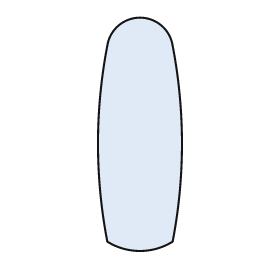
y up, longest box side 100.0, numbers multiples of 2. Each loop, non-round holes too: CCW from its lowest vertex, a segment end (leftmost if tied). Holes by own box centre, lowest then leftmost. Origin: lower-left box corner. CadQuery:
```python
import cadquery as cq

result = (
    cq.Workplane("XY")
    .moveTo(4.0, 4.0)
    .threePointArc((18.0, 0.0), (32.0, 4.0))
    .threePointArc((36.0, 46.0), (32.0, 88.0))
    .threePointArc((18.0, 100.0), (4.0, 88.0))
    .threePointArc((0.0, 46.0), (4.0, 4.0))
    .close()
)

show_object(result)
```